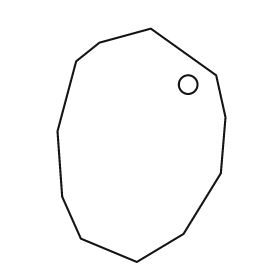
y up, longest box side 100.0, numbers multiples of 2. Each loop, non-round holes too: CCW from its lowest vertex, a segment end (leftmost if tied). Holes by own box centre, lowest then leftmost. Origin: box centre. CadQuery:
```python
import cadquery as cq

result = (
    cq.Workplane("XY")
    .moveTo(-2.0, -50.0)
    .lineTo(18.0, -38.0)
    .lineTo(34.0, -12.0)
    .lineTo(36.0, 12.0)
    .lineTo(32.0, 30.0)
    .lineTo(4.0, 50.0)
    .lineTo(-18.0, 44.0)
    .lineTo(-28.0, 36.0)
    .lineTo(-36.0, 6.0)
    .lineTo(-34.0, -22.0)
    .lineTo(-26.0, -40.0)
    .close()
    .moveTo(20.0, 26.0)
    .circle(4.0)
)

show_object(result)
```